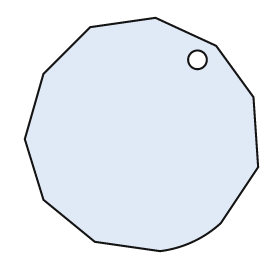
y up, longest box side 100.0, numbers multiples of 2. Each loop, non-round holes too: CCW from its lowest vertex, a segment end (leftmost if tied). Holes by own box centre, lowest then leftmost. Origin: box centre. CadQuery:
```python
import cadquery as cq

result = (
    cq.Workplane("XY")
    .moveTo(8.0, -50.0)
    .threePointArc((22.0, -46.0), (34.0, -38.0))
    .lineTo(50.0, -14.0)
    .lineTo(48.0, 16.0)
    .lineTo(32.0, 38.0)
    .lineTo(6.0, 50.0)
    .lineTo(-22.0, 46.0)
    .lineTo(-42.0, 26.0)
    .lineTo(-50.0, -2.0)
    .lineTo(-42.0, -28.0)
    .lineTo(-20.0, -46.0)
    .close()
    .moveTo(24.0, 32.0)
    .circle(4.0)
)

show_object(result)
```